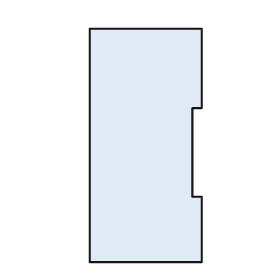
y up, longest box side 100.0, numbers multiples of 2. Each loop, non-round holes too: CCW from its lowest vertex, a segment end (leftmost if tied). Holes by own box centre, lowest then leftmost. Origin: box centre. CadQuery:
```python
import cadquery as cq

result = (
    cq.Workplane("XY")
    .moveTo(-24.0, -50.0)
    .lineTo(24.0, -50.0)
    .lineTo(24.0, -22.0)
    .lineTo(20.0, -22.0)
    .lineTo(20.0, 16.0)
    .lineTo(24.0, 16.0)
    .lineTo(24.0, 50.0)
    .lineTo(-24.0, 50.0)
    .close()
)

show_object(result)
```